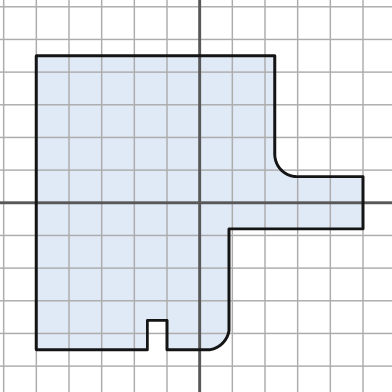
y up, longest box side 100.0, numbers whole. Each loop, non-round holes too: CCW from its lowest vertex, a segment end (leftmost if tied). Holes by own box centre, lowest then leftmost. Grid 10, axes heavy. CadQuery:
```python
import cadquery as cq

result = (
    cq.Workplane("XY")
    .moveTo(-50.0, -45.0)
    .lineTo(-16.0, -45.0)
    .lineTo(-16.0, -36.0)
    .lineTo(-10.0, -36.0)
    .lineTo(-10.0, -45.0)
    .lineTo(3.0, -45.0)
    .threePointArc((7.0, -43.0), (9.0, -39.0))
    .lineTo(9.0, -8.0)
    .lineTo(50.0, -8.0)
    .lineTo(50.0, 8.0)
    .lineTo(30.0, 8.0)
    .threePointArc((25.0, 10.0), (23.0, 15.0))
    .lineTo(23.0, 45.0)
    .lineTo(-50.0, 45.0)
    .close()
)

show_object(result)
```